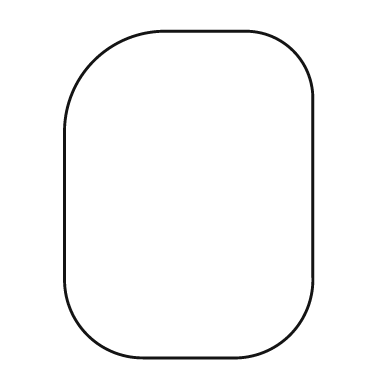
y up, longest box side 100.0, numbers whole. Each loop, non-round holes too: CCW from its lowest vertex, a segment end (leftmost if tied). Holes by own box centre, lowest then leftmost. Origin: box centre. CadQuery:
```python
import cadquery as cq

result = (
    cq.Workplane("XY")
    .moveTo(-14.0, -50.0)
    .lineTo(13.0, -50.0)
    .threePointArc((31.0, -43.0), (38.0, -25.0))
    .lineTo(38.0, 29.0)
    .threePointArc((32.0, 44.0), (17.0, 50.0))
    .lineTo(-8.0, 50.0)
    .threePointArc((-29.0, 41.0), (-38.0, 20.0))
    .lineTo(-38.0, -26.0)
    .threePointArc((-31.0, -43.0), (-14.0, -50.0))
    .close()
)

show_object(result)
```